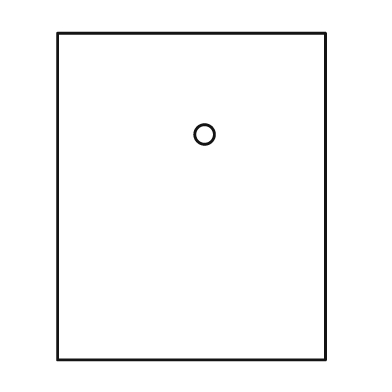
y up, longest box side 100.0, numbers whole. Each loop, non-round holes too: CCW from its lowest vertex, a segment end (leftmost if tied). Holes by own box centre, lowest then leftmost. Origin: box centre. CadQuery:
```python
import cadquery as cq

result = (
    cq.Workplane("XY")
    .moveTo(-41.0, -50.0)
    .lineTo(41.0, -50.0)
    .lineTo(41.0, 50.0)
    .lineTo(-41.0, 50.0)
    .close()
    .moveTo(4.0, 19.0)
    .circle(3.0)
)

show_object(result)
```